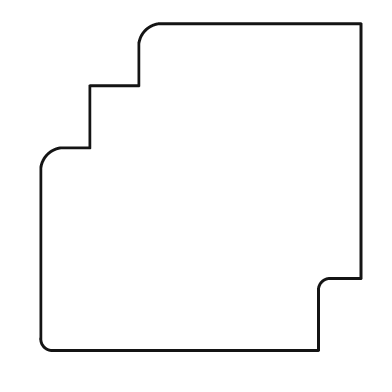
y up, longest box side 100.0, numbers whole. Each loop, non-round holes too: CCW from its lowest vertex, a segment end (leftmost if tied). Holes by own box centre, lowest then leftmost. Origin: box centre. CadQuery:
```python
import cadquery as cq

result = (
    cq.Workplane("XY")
    .moveTo(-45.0, -50.0)
    .lineTo(36.0, -50.0)
    .lineTo(36.0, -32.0)
    .threePointArc((37.0, -29.0), (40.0, -28.0))
    .lineTo(49.0, -28.0)
    .lineTo(49.0, 50.0)
    .lineTo(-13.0, 50.0)
    .threePointArc((-17.0, 48.0), (-19.0, 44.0))
    .lineTo(-19.0, 31.0)
    .lineTo(-34.0, 31.0)
    .lineTo(-34.0, 12.0)
    .lineTo(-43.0, 12.0)
    .threePointArc((-47.0, 10.0), (-49.0, 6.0))
    .lineTo(-49.0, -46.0)
    .threePointArc((-48.0, -49.0), (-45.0, -50.0))
    .close()
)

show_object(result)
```